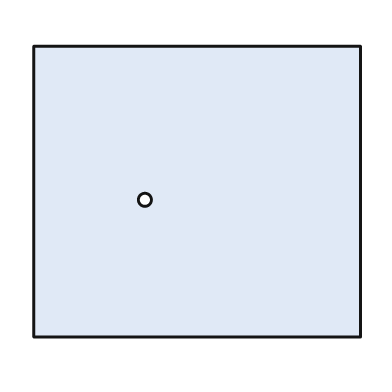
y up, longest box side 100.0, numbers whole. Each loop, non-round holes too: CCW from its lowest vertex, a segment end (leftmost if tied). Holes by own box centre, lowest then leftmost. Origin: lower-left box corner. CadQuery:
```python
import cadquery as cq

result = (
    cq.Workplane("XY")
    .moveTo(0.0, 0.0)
    .lineTo(100.0, 0.0)
    .lineTo(100.0, 89.0)
    .lineTo(0.0, 89.0)
    .close()
    .moveTo(34.0, 42.0)
    .circle(2.0)
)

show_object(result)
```